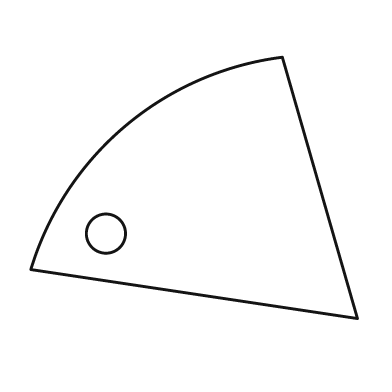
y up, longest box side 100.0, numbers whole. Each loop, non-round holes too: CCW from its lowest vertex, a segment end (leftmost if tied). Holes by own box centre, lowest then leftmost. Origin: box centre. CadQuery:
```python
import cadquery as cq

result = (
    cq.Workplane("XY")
    .moveTo(50.0, -40.0)
    .lineTo(27.0, 40.0)
    .threePointArc((-21.0, 19.0), (-50.0, -25.0))
    .close()
    .moveTo(-27.0, -14.0)
    .circle(6.0)
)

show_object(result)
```